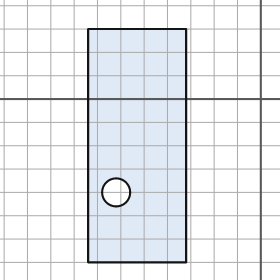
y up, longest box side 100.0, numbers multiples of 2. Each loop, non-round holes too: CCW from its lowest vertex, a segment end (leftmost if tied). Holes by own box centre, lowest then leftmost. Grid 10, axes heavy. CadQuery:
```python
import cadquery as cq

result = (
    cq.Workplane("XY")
    .moveTo(-74.0, -70.0)
    .lineTo(-32.0, -70.0)
    .lineTo(-32.0, 30.0)
    .lineTo(-74.0, 30.0)
    .close()
    .moveTo(-62.0, -40.0)
    .circle(6.0)
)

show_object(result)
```